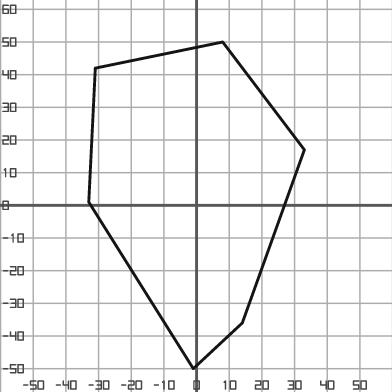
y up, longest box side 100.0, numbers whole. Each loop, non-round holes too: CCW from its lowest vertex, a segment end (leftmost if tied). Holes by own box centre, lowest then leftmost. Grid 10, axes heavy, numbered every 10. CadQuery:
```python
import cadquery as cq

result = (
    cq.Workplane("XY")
    .moveTo(-1.0, -50.0)
    .lineTo(14.0, -36.0)
    .lineTo(33.0, 17.0)
    .lineTo(8.0, 50.0)
    .lineTo(-31.0, 42.0)
    .lineTo(-33.0, 1.0)
    .close()
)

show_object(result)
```